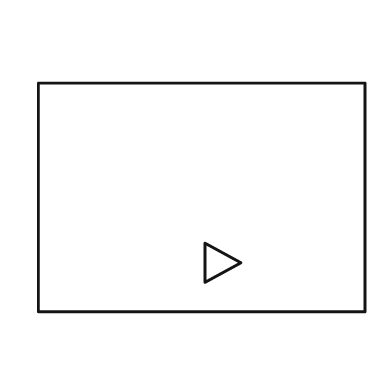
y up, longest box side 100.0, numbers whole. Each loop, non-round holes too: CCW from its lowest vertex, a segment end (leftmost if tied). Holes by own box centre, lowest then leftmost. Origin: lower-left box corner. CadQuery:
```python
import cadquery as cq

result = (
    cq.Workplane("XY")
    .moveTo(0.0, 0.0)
    .lineTo(100.0, 0.0)
    .lineTo(100.0, 70.0)
    .lineTo(0.0, 70.0)
    .close()
    .moveTo(51.0, 9.0)
    .lineTo(62.0, 15.0)
    .lineTo(51.0, 21.0)
    .close()
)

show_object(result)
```